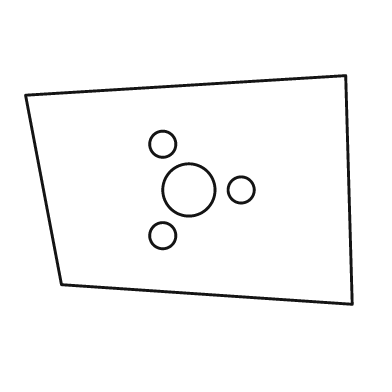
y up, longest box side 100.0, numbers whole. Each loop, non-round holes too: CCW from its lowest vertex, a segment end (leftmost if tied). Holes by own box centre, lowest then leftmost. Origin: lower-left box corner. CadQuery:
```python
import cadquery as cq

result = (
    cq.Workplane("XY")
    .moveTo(100.0, 0.0)
    .lineTo(98.0, 70.0)
    .lineTo(0.0, 64.0)
    .lineTo(11.0, 6.0)
    .close()
    .moveTo(42.0, 21.0)
    .circle(4.0)
    .moveTo(50.0, 35.0)
    .circle(8.0)
    .moveTo(66.0, 35.0)
    .circle(4.0)
    .moveTo(42.0, 49.0)
    .circle(4.0)
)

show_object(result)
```